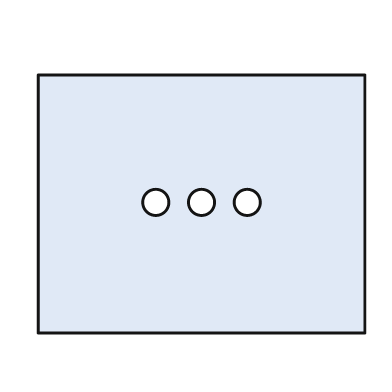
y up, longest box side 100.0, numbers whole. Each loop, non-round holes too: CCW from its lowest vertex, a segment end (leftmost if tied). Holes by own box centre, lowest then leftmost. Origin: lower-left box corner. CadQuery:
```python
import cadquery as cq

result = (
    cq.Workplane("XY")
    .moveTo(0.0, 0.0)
    .lineTo(100.0, 0.0)
    .lineTo(100.0, 79.0)
    .lineTo(0.0, 79.0)
    .close()
    .moveTo(36.0, 40.0)
    .circle(4.0)
    .moveTo(50.0, 40.0)
    .circle(4.0)
    .moveTo(64.0, 40.0)
    .circle(4.0)
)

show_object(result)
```